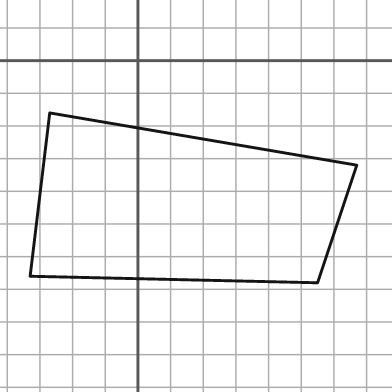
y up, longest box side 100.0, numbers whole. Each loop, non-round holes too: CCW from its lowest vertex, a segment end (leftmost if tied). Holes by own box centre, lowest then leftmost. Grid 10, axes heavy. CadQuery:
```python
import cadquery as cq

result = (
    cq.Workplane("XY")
    .moveTo(55.0, -68.0)
    .lineTo(67.0, -32.0)
    .lineTo(-27.0, -16.0)
    .lineTo(-33.0, -66.0)
    .close()
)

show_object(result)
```